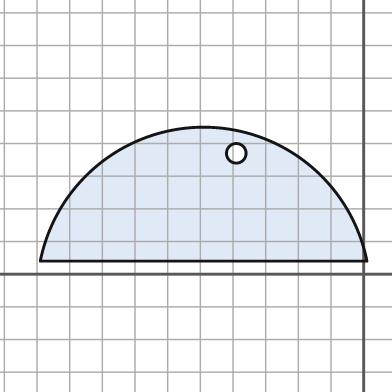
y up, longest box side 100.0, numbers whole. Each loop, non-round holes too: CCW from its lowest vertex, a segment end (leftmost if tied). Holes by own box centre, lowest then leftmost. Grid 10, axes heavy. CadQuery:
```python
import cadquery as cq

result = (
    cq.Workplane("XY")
    .moveTo(-99.0, 4.0)
    .lineTo(1.0, 4.0)
    .threePointArc((-49.0, 45.0), (-99.0, 4.0))
    .close()
    .moveTo(-39.0, 37.0)
    .circle(3.0)
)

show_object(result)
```